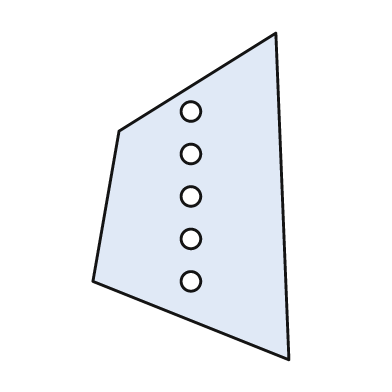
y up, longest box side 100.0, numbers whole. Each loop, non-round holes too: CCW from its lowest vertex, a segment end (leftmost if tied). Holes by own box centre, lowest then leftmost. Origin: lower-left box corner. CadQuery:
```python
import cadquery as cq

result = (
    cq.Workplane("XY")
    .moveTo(60.0, 0.0)
    .lineTo(56.0, 100.0)
    .lineTo(8.0, 70.0)
    .lineTo(0.0, 24.0)
    .close()
    .moveTo(30.0, 24.0)
    .circle(3.0)
    .moveTo(30.0, 37.0)
    .circle(3.0)
    .moveTo(30.0, 50.0)
    .circle(3.0)
    .moveTo(30.0, 63.0)
    .circle(3.0)
    .moveTo(30.0, 76.0)
    .circle(3.0)
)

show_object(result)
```